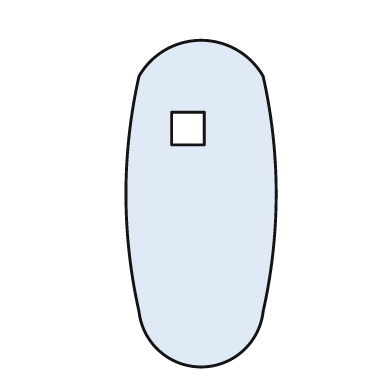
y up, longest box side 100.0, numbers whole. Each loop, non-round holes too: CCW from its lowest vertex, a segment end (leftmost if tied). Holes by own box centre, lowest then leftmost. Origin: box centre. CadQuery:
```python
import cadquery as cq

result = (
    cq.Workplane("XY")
    .moveTo(-19.0, -33.0)
    .threePointArc((0.0, -50.0), (19.0, -33.0))
    .threePointArc((23.0, 3.0), (19.0, 39.0))
    .threePointArc((0.0, 50.0), (-19.0, 39.0))
    .threePointArc((-23.0, 3.0), (-19.0, -33.0))
    .close()
    .moveTo(-9.0, 18.0)
    .lineTo(1.0, 18.0)
    .lineTo(1.0, 28.0)
    .lineTo(-9.0, 28.0)
    .close()
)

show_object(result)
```